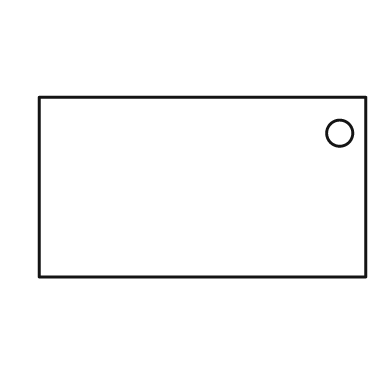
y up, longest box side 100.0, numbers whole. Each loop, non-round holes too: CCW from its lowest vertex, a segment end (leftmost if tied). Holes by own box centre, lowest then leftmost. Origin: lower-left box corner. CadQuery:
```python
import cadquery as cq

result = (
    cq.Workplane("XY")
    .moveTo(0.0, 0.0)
    .lineTo(100.0, 0.0)
    .lineTo(100.0, 55.0)
    .lineTo(0.0, 55.0)
    .close()
    .moveTo(92.0, 44.0)
    .circle(4.0)
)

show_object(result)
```